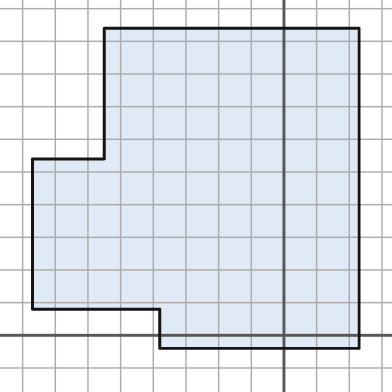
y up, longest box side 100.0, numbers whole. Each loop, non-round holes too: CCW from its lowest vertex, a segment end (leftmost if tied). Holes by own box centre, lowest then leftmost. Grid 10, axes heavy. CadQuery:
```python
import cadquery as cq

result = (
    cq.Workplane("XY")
    .moveTo(-38.0, -4.0)
    .lineTo(23.0, -4.0)
    .lineTo(23.0, 94.0)
    .lineTo(-55.0, 94.0)
    .lineTo(-55.0, 54.0)
    .lineTo(-77.0, 54.0)
    .lineTo(-77.0, 8.0)
    .lineTo(-38.0, 8.0)
    .close()
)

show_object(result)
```